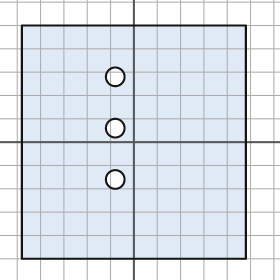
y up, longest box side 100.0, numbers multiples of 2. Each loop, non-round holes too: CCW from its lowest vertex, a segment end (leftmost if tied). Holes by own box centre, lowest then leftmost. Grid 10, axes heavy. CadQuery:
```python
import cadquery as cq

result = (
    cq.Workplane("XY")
    .moveTo(-48.0, -50.0)
    .lineTo(48.0, -50.0)
    .lineTo(48.0, 50.0)
    .lineTo(-48.0, 50.0)
    .close()
    .moveTo(-8.0, -16.0)
    .circle(4.0)
    .moveTo(-8.0, 6.0)
    .circle(4.0)
    .moveTo(-8.0, 28.0)
    .circle(4.0)
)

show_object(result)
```